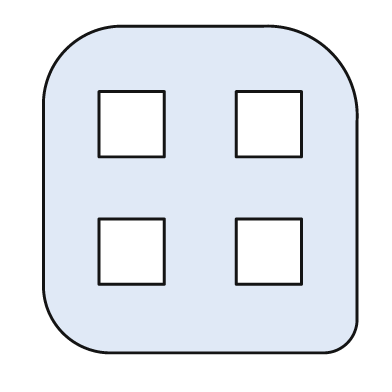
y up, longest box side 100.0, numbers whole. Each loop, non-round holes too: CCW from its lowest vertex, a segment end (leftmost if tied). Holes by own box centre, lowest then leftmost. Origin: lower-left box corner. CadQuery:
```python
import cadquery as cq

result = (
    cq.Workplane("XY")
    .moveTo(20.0, 0.0)
    .lineTo(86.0, 0.0)
    .threePointArc((93.0, 3.0), (96.0, 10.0))
    .lineTo(96.0, 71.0)
    .threePointArc((88.0, 92.0), (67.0, 100.0))
    .lineTo(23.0, 100.0)
    .threePointArc((7.0, 93.0), (0.0, 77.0))
    .lineTo(0.0, 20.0)
    .threePointArc((6.0, 6.0), (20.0, 0.0))
    .close()
    .moveTo(17.0, 21.0)
    .lineTo(37.0, 21.0)
    .lineTo(37.0, 41.0)
    .lineTo(17.0, 41.0)
    .close()
    .moveTo(59.0, 21.0)
    .lineTo(79.0, 21.0)
    .lineTo(79.0, 41.0)
    .lineTo(59.0, 41.0)
    .close()
    .moveTo(17.0, 60.0)
    .lineTo(37.0, 60.0)
    .lineTo(37.0, 80.0)
    .lineTo(17.0, 80.0)
    .close()
    .moveTo(59.0, 60.0)
    .lineTo(79.0, 60.0)
    .lineTo(79.0, 80.0)
    .lineTo(59.0, 80.0)
    .close()
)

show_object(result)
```